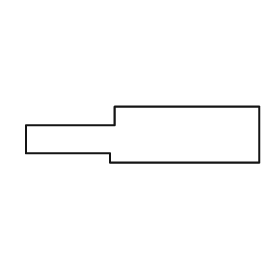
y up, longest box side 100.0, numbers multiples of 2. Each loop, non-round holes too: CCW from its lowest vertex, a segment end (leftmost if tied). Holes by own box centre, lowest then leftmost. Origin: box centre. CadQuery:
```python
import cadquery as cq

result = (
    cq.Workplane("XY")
    .moveTo(-14.0, -12.0)
    .lineTo(50.0, -12.0)
    .lineTo(50.0, 12.0)
    .lineTo(-12.0, 12.0)
    .lineTo(-12.0, 4.0)
    .lineTo(-50.0, 4.0)
    .lineTo(-50.0, -8.0)
    .lineTo(-14.0, -8.0)
    .close()
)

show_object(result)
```